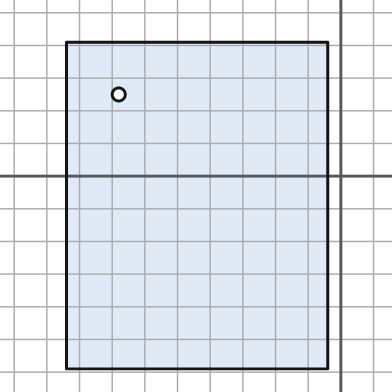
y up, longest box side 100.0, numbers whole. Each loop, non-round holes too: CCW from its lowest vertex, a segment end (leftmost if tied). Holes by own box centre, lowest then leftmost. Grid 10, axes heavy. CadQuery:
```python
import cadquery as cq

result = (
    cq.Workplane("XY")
    .moveTo(-84.0, -59.0)
    .lineTo(-4.0, -59.0)
    .lineTo(-4.0, 41.0)
    .lineTo(-84.0, 41.0)
    .close()
    .moveTo(-68.0, 25.0)
    .circle(2.0)
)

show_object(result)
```